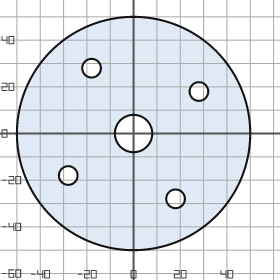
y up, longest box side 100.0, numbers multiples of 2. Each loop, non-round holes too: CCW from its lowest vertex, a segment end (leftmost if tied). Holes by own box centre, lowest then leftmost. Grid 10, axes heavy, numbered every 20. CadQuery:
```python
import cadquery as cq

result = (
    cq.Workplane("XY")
    .moveTo(0.0, 0.0)
    .circle(50.0)
    .moveTo(18.0, -28.0)
    .circle(4.0)
    .moveTo(-28.0, -18.0)
    .circle(4.0)
    .moveTo(0.0, 0.0)
    .circle(8.0)
    .moveTo(28.0, 18.0)
    .circle(4.0)
    .moveTo(-18.0, 28.0)
    .circle(4.0)
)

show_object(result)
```